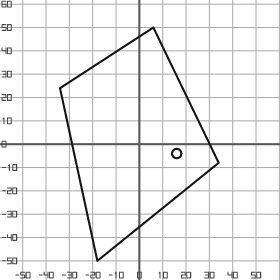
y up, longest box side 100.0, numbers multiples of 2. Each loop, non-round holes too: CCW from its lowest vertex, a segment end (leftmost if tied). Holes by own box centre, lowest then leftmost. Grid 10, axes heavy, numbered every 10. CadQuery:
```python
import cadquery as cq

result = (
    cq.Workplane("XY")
    .moveTo(-18.0, -50.0)
    .lineTo(34.0, -8.0)
    .lineTo(6.0, 50.0)
    .lineTo(-34.0, 24.0)
    .close()
    .moveTo(16.0, -4.0)
    .circle(2.0)
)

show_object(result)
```